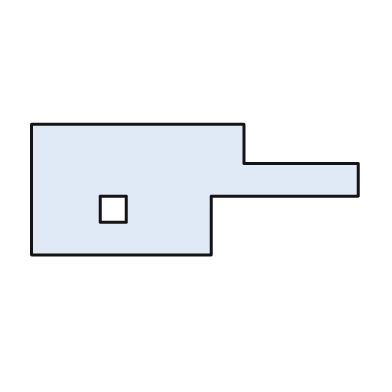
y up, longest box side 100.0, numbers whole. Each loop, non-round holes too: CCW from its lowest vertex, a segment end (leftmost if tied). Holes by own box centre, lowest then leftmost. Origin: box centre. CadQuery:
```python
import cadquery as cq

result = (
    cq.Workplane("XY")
    .moveTo(-50.0, -20.0)
    .lineTo(5.0, -20.0)
    .lineTo(5.0, -2.0)
    .lineTo(50.0, -2.0)
    .lineTo(50.0, 8.0)
    .lineTo(15.0, 8.0)
    .lineTo(15.0, 20.0)
    .lineTo(-50.0, 20.0)
    .close()
    .moveTo(-29.0, -10.0)
    .lineTo(-21.0, -10.0)
    .lineTo(-21.0, -2.0)
    .lineTo(-29.0, -2.0)
    .close()
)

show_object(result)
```